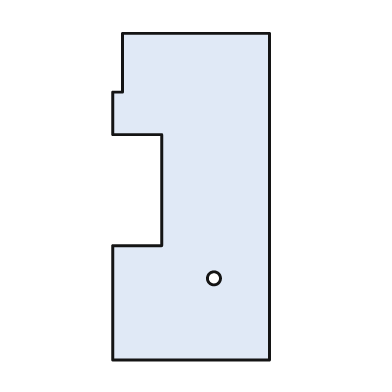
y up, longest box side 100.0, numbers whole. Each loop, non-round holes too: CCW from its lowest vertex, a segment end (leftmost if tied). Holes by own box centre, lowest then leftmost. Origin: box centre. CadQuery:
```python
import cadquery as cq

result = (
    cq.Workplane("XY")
    .moveTo(-24.0, -50.0)
    .lineTo(24.0, -50.0)
    .lineTo(24.0, 50.0)
    .lineTo(-21.0, 50.0)
    .lineTo(-21.0, 32.0)
    .lineTo(-24.0, 32.0)
    .lineTo(-24.0, 19.0)
    .lineTo(-9.0, 19.0)
    .lineTo(-9.0, -15.0)
    .lineTo(-24.0, -15.0)
    .close()
    .moveTo(7.0, -25.0)
    .circle(2.0)
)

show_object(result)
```